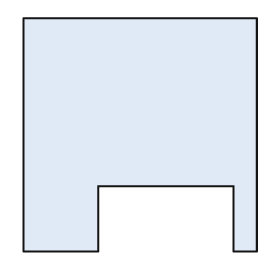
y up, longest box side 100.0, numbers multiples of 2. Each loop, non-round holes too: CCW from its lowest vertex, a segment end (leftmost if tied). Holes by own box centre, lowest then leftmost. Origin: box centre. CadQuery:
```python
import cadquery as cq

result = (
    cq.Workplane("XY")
    .moveTo(-50.0, -50.0)
    .lineTo(-18.0, -50.0)
    .lineTo(-18.0, -22.0)
    .lineTo(40.0, -22.0)
    .lineTo(40.0, -50.0)
    .lineTo(50.0, -50.0)
    .lineTo(50.0, 50.0)
    .lineTo(-50.0, 50.0)
    .close()
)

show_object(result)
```